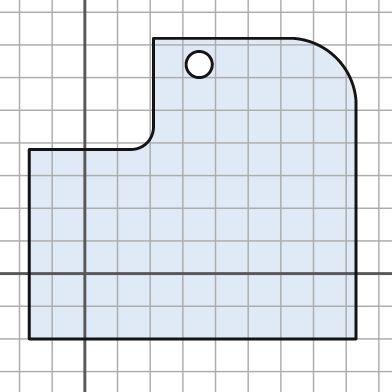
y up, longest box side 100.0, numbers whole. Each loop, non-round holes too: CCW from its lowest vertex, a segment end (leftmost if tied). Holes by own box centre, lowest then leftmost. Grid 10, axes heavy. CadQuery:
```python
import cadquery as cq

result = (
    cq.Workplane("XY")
    .moveTo(-17.0, -20.0)
    .lineTo(83.0, -20.0)
    .lineTo(83.0, 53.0)
    .threePointArc((77.0, 66.0), (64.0, 72.0))
    .lineTo(21.0, 72.0)
    .lineTo(21.0, 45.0)
    .threePointArc((19.0, 40.0), (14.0, 38.0))
    .lineTo(-17.0, 38.0)
    .close()
    .moveTo(35.0, 64.0)
    .circle(4.0)
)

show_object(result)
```